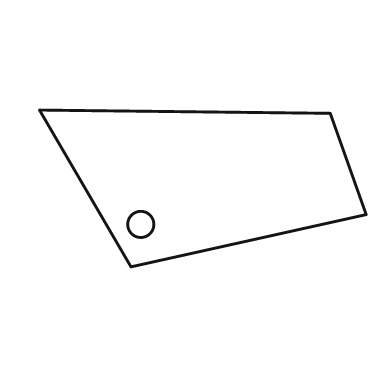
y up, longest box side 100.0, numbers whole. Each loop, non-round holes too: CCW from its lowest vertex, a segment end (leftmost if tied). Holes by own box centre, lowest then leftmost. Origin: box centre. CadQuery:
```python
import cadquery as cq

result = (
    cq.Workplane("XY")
    .moveTo(-22.0, -24.0)
    .lineTo(50.0, -8.0)
    .lineTo(39.0, 23.0)
    .lineTo(-50.0, 24.0)
    .close()
    .moveTo(-19.0, -11.0)
    .circle(4.0)
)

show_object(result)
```